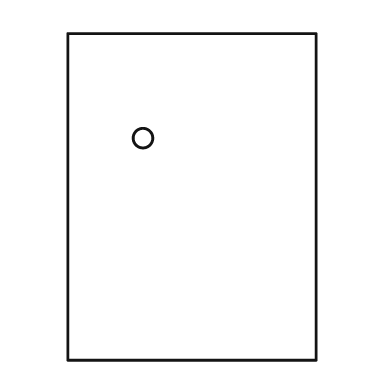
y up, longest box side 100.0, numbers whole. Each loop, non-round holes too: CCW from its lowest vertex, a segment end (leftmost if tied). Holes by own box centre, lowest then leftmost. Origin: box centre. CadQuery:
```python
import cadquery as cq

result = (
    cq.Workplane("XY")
    .moveTo(-38.0, -50.0)
    .lineTo(38.0, -50.0)
    .lineTo(38.0, 50.0)
    .lineTo(-38.0, 50.0)
    .close()
    .moveTo(-15.0, 18.0)
    .circle(3.0)
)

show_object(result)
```